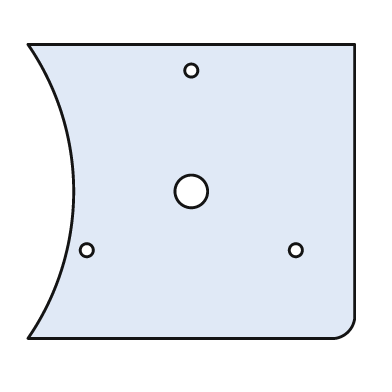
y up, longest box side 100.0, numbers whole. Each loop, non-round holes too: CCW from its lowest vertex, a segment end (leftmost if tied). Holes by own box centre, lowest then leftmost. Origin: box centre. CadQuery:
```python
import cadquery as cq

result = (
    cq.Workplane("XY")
    .moveTo(-50.0, -45.0)
    .lineTo(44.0, -45.0)
    .threePointArc((48.0, -43.0), (50.0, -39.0))
    .lineTo(50.0, 45.0)
    .lineTo(-50.0, 45.0)
    .threePointArc((-36.0, 0.0), (-50.0, -45.0))
    .close()
    .moveTo(-32.0, -18.0)
    .circle(2.0)
    .moveTo(32.0, -18.0)
    .circle(2.0)
    .moveTo(0.0, 0.0)
    .circle(5.0)
    .moveTo(0.0, 37.0)
    .circle(2.0)
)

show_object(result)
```